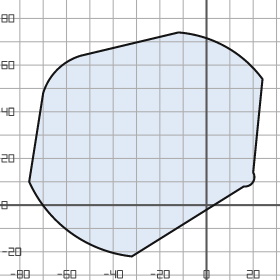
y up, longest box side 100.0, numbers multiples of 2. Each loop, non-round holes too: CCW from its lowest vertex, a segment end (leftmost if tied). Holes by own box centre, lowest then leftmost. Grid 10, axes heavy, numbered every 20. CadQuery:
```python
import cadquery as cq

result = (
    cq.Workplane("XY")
    .moveTo(-32.0, -22.0)
    .lineTo(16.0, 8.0)
    .threePointArc((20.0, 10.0), (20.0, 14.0))
    .lineTo(24.0, 54.0)
    .threePointArc((8.0, 68.0), (-12.0, 74.0))
    .lineTo(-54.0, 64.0)
    .threePointArc((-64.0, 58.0), (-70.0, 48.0))
    .lineTo(-76.0, 10.0)
    .threePointArc((-58.0, -12.0), (-32.0, -22.0))
    .close()
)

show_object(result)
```